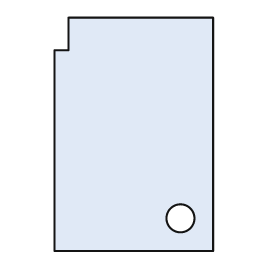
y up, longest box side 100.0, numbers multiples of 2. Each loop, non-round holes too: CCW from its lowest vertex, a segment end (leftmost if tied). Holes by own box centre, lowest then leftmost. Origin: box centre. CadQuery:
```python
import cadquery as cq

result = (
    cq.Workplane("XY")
    .moveTo(-34.0, -50.0)
    .lineTo(34.0, -50.0)
    .lineTo(34.0, 50.0)
    .lineTo(-28.0, 50.0)
    .lineTo(-28.0, 36.0)
    .lineTo(-34.0, 36.0)
    .close()
    .moveTo(20.0, -36.0)
    .circle(6.0)
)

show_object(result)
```